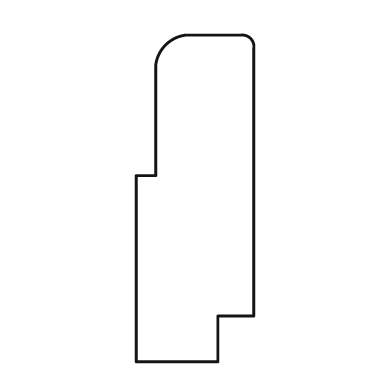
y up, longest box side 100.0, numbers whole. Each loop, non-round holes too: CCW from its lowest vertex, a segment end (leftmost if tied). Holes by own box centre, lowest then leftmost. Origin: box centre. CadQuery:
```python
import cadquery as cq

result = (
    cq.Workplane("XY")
    .moveTo(-18.0, -50.0)
    .lineTo(7.0, -50.0)
    .lineTo(7.0, -36.0)
    .lineTo(18.0, -36.0)
    .lineTo(18.0, 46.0)
    .threePointArc((17.0, 49.0), (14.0, 50.0))
    .lineTo(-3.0, 50.0)
    .threePointArc((-9.0, 47.0), (-12.0, 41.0))
    .lineTo(-12.0, 7.0)
    .lineTo(-18.0, 7.0)
    .close()
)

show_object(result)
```